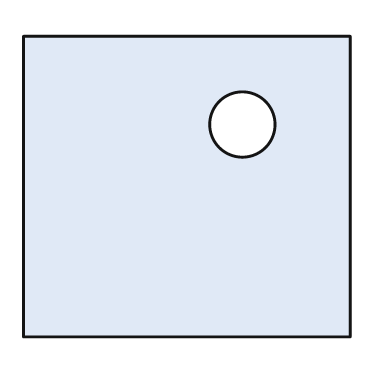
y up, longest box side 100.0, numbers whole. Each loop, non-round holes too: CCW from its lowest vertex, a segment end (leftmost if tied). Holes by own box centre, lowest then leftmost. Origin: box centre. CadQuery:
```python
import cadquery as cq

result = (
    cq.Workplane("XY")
    .moveTo(-50.0, -46.0)
    .lineTo(50.0, -46.0)
    .lineTo(50.0, 46.0)
    .lineTo(-50.0, 46.0)
    .close()
    .moveTo(17.0, 19.0)
    .circle(10.0)
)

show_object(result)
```